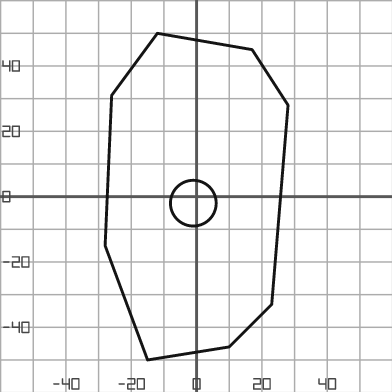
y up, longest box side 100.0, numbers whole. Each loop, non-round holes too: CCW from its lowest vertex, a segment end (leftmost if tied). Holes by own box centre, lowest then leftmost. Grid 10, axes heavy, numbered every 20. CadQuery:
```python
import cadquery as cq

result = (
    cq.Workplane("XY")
    .moveTo(-15.0, -50.0)
    .lineTo(10.0, -46.0)
    .lineTo(23.0, -33.0)
    .lineTo(28.0, 28.0)
    .lineTo(17.0, 45.0)
    .lineTo(-12.0, 50.0)
    .lineTo(-26.0, 31.0)
    .lineTo(-28.0, -15.0)
    .close()
    .moveTo(-1.0, -2.0)
    .circle(7.0)
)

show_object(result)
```